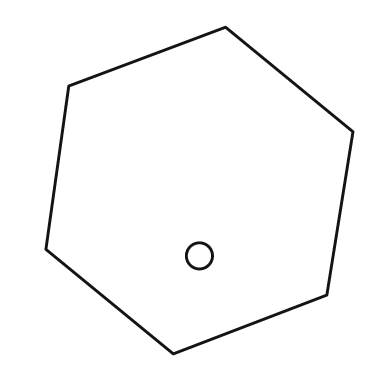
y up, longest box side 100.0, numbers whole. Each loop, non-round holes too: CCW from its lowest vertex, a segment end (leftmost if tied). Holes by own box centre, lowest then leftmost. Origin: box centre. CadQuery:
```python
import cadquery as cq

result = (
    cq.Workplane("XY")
    .moveTo(-8.0, -50.0)
    .lineTo(39.0, -32.0)
    .lineTo(47.0, 18.0)
    .lineTo(8.0, 50.0)
    .lineTo(-40.0, 32.0)
    .lineTo(-47.0, -18.0)
    .close()
    .moveTo(0.0, -20.0)
    .circle(4.0)
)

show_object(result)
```